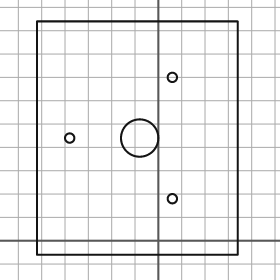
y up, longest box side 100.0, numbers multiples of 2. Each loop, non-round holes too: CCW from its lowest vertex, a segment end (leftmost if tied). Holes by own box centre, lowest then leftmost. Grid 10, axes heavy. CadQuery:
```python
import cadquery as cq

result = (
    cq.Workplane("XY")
    .moveTo(-52.0, -6.0)
    .lineTo(34.0, -6.0)
    .lineTo(34.0, 94.0)
    .lineTo(-52.0, 94.0)
    .close()
    .moveTo(6.0, 18.0)
    .circle(2.0)
    .moveTo(-38.0, 44.0)
    .circle(2.0)
    .moveTo(-8.0, 44.0)
    .circle(8.0)
    .moveTo(6.0, 70.0)
    .circle(2.0)
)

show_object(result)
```